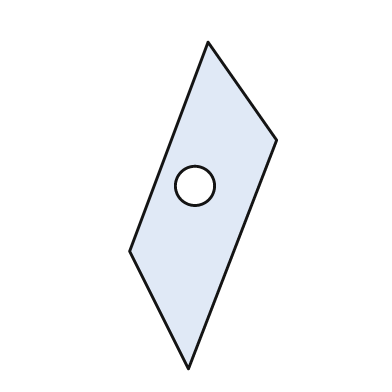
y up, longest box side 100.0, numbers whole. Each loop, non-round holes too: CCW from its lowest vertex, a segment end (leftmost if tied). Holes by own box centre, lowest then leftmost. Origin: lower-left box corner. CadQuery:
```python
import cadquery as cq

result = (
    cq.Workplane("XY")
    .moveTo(18.0, 0.0)
    .lineTo(45.0, 70.0)
    .lineTo(24.0, 100.0)
    .lineTo(0.0, 36.0)
    .close()
    .moveTo(20.0, 56.0)
    .circle(6.0)
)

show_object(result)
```